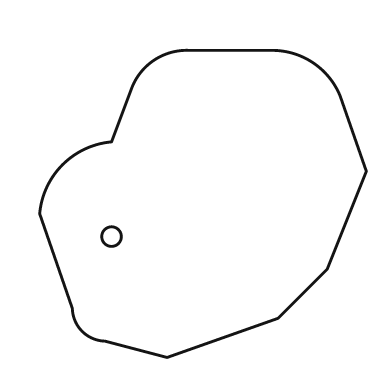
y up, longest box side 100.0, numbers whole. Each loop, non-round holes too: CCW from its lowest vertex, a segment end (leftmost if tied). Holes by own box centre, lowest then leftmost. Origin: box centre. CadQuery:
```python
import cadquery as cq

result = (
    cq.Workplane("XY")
    .moveTo(-11.0, -47.0)
    .lineTo(23.0, -35.0)
    .lineTo(38.0, -20.0)
    .lineTo(50.0, 10.0)
    .lineTo(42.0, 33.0)
    .threePointArc((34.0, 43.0), (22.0, 47.0))
    .lineTo(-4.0, 47.0)
    .threePointArc((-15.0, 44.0), (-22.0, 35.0))
    .lineTo(-28.0, 19.0)
    .threePointArc((-43.0, 12.0), (-50.0, -3.0))
    .lineTo(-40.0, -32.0)
    .threePointArc((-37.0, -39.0), (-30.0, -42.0))
    .close()
    .moveTo(-28.0, -10.0)
    .circle(3.0)
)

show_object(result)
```